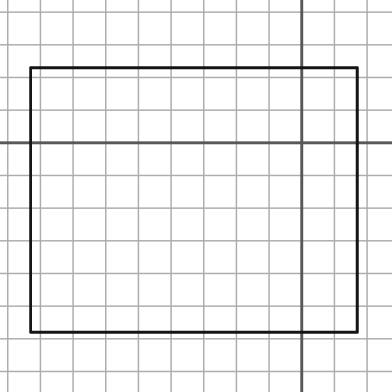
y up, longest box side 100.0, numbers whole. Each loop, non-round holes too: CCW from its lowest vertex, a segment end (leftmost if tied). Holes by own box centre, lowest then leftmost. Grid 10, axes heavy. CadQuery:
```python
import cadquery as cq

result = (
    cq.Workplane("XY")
    .moveTo(-83.0, -58.0)
    .lineTo(17.0, -58.0)
    .lineTo(17.0, 23.0)
    .lineTo(-83.0, 23.0)
    .close()
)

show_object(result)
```